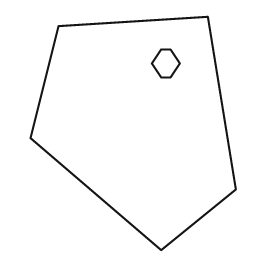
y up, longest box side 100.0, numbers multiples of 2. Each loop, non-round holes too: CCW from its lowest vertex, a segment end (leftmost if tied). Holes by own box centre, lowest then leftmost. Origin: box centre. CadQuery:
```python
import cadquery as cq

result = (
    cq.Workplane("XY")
    .moveTo(12.0, -50.0)
    .lineTo(44.0, -24.0)
    .lineTo(32.0, 50.0)
    .lineTo(-32.0, 46.0)
    .lineTo(-44.0, -2.0)
    .close()
    .moveTo(12.0, 24.0)
    .lineTo(16.0, 24.0)
    .lineTo(20.0, 30.0)
    .lineTo(16.0, 36.0)
    .lineTo(12.0, 36.0)
    .lineTo(8.0, 30.0)
    .close()
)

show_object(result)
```